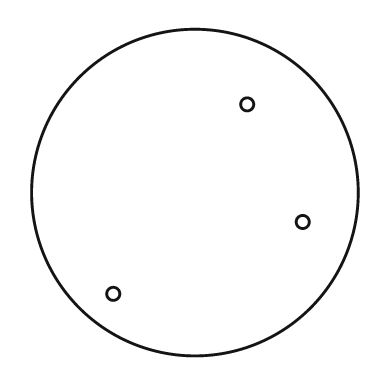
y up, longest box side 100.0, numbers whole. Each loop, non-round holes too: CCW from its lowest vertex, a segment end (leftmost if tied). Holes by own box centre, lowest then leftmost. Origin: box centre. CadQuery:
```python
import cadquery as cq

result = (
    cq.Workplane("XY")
    .moveTo(0.0, 0.0)
    .circle(50.0)
    .moveTo(-25.0, -31.0)
    .circle(2.0)
    .moveTo(33.0, -9.0)
    .circle(2.0)
    .moveTo(16.0, 27.0)
    .circle(2.0)
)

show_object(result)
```